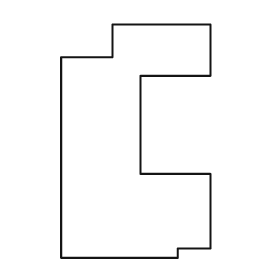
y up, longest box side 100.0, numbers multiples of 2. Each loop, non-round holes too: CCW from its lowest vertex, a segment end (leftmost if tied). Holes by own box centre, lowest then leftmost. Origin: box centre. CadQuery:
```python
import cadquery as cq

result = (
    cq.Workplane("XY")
    .moveTo(-32.0, -50.0)
    .lineTo(18.0, -50.0)
    .lineTo(18.0, -46.0)
    .lineTo(32.0, -46.0)
    .lineTo(32.0, -14.0)
    .lineTo(2.0, -14.0)
    .lineTo(2.0, 28.0)
    .lineTo(32.0, 28.0)
    .lineTo(32.0, 50.0)
    .lineTo(-10.0, 50.0)
    .lineTo(-10.0, 36.0)
    .lineTo(-32.0, 36.0)
    .close()
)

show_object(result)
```